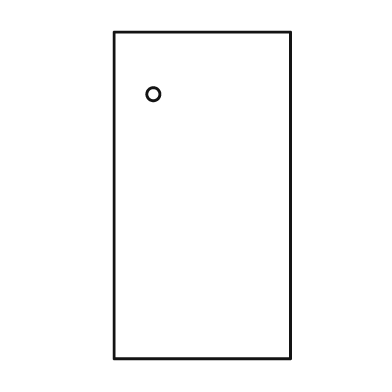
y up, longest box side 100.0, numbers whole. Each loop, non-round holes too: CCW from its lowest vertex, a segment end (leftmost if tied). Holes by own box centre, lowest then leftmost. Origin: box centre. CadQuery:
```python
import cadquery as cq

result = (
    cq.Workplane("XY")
    .moveTo(-27.0, -50.0)
    .lineTo(27.0, -50.0)
    .lineTo(27.0, 50.0)
    .lineTo(-27.0, 50.0)
    .close()
    .moveTo(-15.0, 31.0)
    .circle(2.0)
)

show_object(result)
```